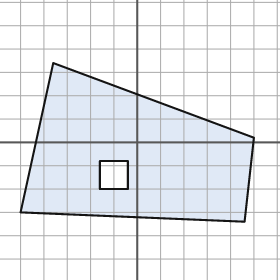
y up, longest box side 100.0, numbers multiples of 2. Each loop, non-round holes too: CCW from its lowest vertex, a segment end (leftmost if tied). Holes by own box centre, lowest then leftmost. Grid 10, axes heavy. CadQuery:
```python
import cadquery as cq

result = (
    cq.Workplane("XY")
    .moveTo(46.0, -34.0)
    .lineTo(50.0, 2.0)
    .lineTo(-36.0, 34.0)
    .lineTo(-50.0, -30.0)
    .close()
    .moveTo(-16.0, -20.0)
    .lineTo(-4.0, -20.0)
    .lineTo(-4.0, -8.0)
    .lineTo(-16.0, -8.0)
    .close()
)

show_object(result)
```